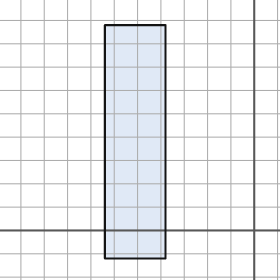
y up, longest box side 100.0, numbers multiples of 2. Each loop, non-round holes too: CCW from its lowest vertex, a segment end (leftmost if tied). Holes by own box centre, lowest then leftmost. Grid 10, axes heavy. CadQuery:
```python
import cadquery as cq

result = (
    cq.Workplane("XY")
    .moveTo(-64.0, -12.0)
    .lineTo(-38.0, -12.0)
    .lineTo(-38.0, 88.0)
    .lineTo(-64.0, 88.0)
    .close()
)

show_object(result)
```